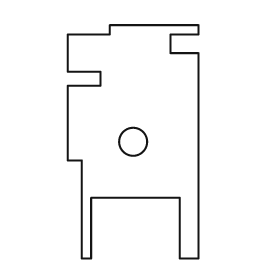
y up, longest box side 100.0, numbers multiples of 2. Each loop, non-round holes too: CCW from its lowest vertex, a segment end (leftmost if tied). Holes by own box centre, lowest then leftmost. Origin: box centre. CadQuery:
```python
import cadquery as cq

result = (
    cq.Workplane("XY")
    .moveTo(-22.0, -50.0)
    .lineTo(-18.0, -50.0)
    .lineTo(-18.0, -24.0)
    .lineTo(20.0, -24.0)
    .lineTo(20.0, -50.0)
    .lineTo(28.0, -50.0)
    .lineTo(28.0, 38.0)
    .lineTo(16.0, 38.0)
    .lineTo(16.0, 46.0)
    .lineTo(28.0, 46.0)
    .lineTo(28.0, 50.0)
    .lineTo(-10.0, 50.0)
    .lineTo(-10.0, 46.0)
    .lineTo(-28.0, 46.0)
    .lineTo(-28.0, 30.0)
    .lineTo(-14.0, 30.0)
    .lineTo(-14.0, 24.0)
    .lineTo(-28.0, 24.0)
    .lineTo(-28.0, -8.0)
    .lineTo(-22.0, -8.0)
    .close()
    .moveTo(0.0, 0.0)
    .circle(6.0)
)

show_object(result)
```